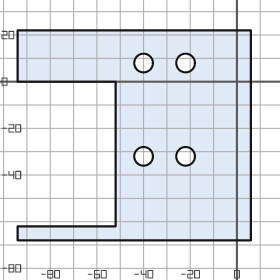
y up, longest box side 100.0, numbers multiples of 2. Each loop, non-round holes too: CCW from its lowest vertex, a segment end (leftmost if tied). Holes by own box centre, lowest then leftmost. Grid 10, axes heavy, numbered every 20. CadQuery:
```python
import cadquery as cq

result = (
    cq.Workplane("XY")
    .moveTo(-94.0, -68.0)
    .lineTo(6.0, -68.0)
    .lineTo(6.0, 22.0)
    .lineTo(-94.0, 22.0)
    .lineTo(-94.0, 0.0)
    .lineTo(-52.0, 0.0)
    .lineTo(-52.0, -62.0)
    .lineTo(-94.0, -62.0)
    .close()
    .moveTo(-40.0, -32.0)
    .circle(4.0)
    .moveTo(-22.0, -32.0)
    .circle(4.0)
    .moveTo(-40.0, 8.0)
    .circle(4.0)
    .moveTo(-22.0, 8.0)
    .circle(4.0)
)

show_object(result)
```